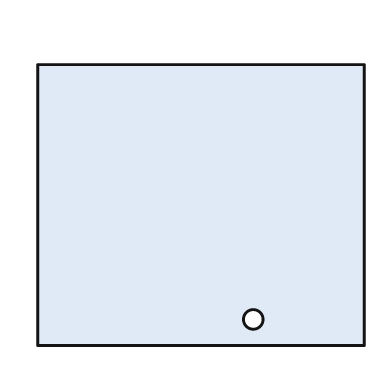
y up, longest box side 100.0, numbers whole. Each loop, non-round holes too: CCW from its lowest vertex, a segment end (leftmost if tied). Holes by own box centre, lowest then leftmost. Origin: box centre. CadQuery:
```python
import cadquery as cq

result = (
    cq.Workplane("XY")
    .moveTo(-50.0, -43.0)
    .lineTo(50.0, -43.0)
    .lineTo(50.0, 43.0)
    .lineTo(-50.0, 43.0)
    .close()
    .moveTo(16.0, -35.0)
    .circle(3.0)
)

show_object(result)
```